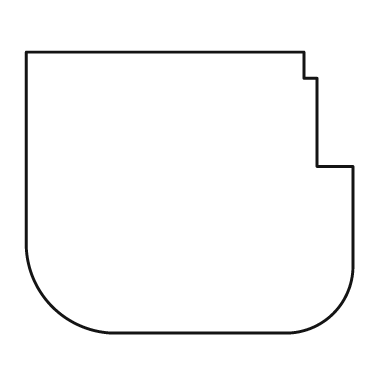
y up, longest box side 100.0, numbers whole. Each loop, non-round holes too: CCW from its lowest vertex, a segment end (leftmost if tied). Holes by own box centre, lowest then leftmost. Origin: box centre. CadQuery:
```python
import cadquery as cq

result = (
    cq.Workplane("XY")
    .moveTo(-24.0, -43.0)
    .lineTo(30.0, -43.0)
    .threePointArc((44.0, -37.0), (50.0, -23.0))
    .lineTo(50.0, 8.0)
    .lineTo(39.0, 8.0)
    .lineTo(39.0, 35.0)
    .lineTo(35.0, 35.0)
    .lineTo(35.0, 43.0)
    .lineTo(-50.0, 43.0)
    .lineTo(-50.0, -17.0)
    .threePointArc((-42.0, -35.0), (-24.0, -43.0))
    .close()
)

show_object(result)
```